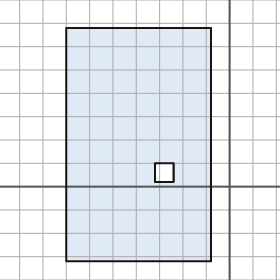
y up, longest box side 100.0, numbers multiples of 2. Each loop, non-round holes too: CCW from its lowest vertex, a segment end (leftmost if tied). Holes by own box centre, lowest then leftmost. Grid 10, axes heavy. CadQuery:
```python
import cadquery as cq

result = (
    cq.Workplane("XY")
    .moveTo(-70.0, -32.0)
    .lineTo(-8.0, -32.0)
    .lineTo(-8.0, 68.0)
    .lineTo(-70.0, 68.0)
    .close()
    .moveTo(-32.0, 2.0)
    .lineTo(-24.0, 2.0)
    .lineTo(-24.0, 10.0)
    .lineTo(-32.0, 10.0)
    .close()
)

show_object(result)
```